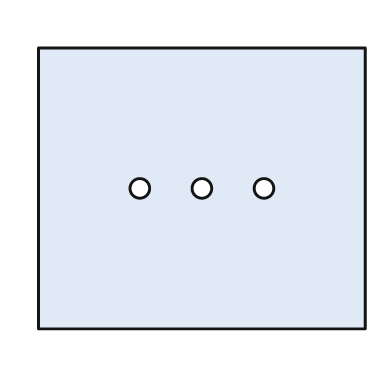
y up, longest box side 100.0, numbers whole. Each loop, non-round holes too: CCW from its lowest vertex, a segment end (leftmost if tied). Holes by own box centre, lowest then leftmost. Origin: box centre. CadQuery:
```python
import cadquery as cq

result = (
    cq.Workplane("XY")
    .moveTo(-50.0, -43.0)
    .lineTo(50.0, -43.0)
    .lineTo(50.0, 43.0)
    .lineTo(-50.0, 43.0)
    .close()
    .moveTo(-19.0, 0.0)
    .circle(3.0)
    .moveTo(0.0, 0.0)
    .circle(3.0)
    .moveTo(19.0, 0.0)
    .circle(3.0)
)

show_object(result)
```